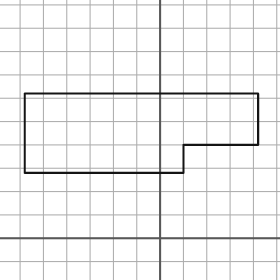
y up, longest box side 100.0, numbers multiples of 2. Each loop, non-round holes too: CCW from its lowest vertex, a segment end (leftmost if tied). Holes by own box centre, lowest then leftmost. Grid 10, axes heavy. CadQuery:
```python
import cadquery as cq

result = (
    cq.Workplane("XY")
    .moveTo(-58.0, 28.0)
    .lineTo(10.0, 28.0)
    .lineTo(10.0, 40.0)
    .lineTo(42.0, 40.0)
    .lineTo(42.0, 62.0)
    .lineTo(-58.0, 62.0)
    .close()
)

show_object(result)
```